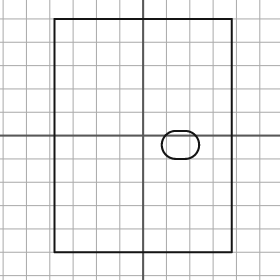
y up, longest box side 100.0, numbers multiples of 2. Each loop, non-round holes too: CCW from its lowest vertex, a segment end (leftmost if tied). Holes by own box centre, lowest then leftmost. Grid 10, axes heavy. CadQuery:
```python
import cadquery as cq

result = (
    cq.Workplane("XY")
    .moveTo(-38.0, -50.0)
    .lineTo(38.0, -50.0)
    .lineTo(38.0, 50.0)
    .lineTo(-38.0, 50.0)
    .close()
    .moveTo(14.0, -10.0)
    .lineTo(18.0, -10.0)
    .threePointArc((24.0, -4.0), (18.0, 2.0))
    .lineTo(14.0, 2.0)
    .threePointArc((8.0, -4.0), (14.0, -10.0))
    .close()
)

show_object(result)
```